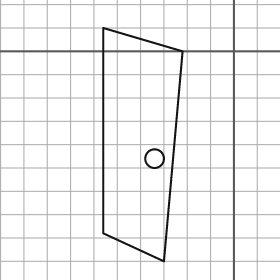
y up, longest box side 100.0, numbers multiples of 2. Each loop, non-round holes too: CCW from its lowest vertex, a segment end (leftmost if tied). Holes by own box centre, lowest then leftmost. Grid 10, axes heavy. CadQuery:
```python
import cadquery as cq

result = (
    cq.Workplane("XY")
    .moveTo(-30.0, -90.0)
    .lineTo(-22.0, 0.0)
    .lineTo(-56.0, 10.0)
    .lineTo(-56.0, -78.0)
    .close()
    .moveTo(-34.0, -46.0)
    .circle(4.0)
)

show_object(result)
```